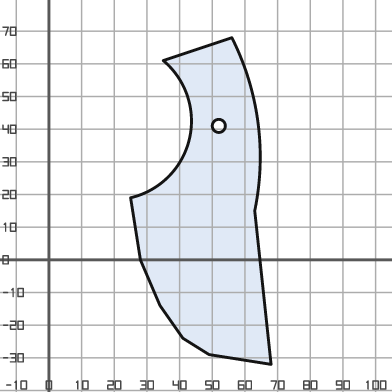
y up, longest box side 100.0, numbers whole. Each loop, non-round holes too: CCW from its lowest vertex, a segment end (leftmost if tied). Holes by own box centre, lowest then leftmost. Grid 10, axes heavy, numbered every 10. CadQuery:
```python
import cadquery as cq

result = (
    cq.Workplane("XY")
    .moveTo(68.0, -32.0)
    .lineTo(63.0, 15.0)
    .threePointArc((64.0, 42.0), (56.0, 68.0))
    .lineTo(35.0, 61.0)
    .threePointArc((43.0, 37.0), (25.0, 19.0))
    .lineTo(28.0, 0.0)
    .lineTo(34.0, -14.0)
    .lineTo(41.0, -24.0)
    .lineTo(49.0, -29.0)
    .close()
    .moveTo(52.0, 41.0)
    .circle(2.0)
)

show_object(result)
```